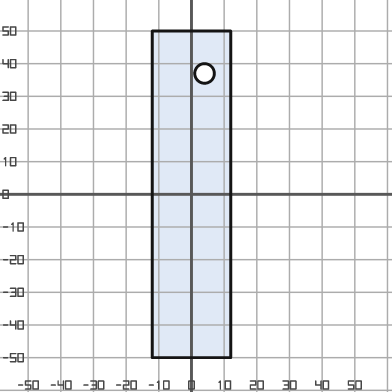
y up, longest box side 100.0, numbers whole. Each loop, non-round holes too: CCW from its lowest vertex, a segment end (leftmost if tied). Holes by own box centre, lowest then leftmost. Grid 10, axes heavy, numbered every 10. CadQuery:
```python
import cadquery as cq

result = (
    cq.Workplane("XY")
    .moveTo(-12.0, -50.0)
    .lineTo(12.0, -50.0)
    .lineTo(12.0, 50.0)
    .lineTo(-12.0, 50.0)
    .close()
    .moveTo(4.0, 37.0)
    .circle(3.0)
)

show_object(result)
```